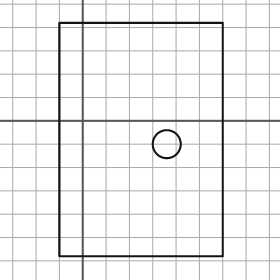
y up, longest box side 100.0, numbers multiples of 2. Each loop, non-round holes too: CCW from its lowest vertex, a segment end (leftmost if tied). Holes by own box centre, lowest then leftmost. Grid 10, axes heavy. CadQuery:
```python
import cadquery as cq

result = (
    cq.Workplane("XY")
    .moveTo(-10.0, -58.0)
    .lineTo(60.0, -58.0)
    .lineTo(60.0, 42.0)
    .lineTo(-10.0, 42.0)
    .close()
    .moveTo(36.0, -10.0)
    .circle(6.0)
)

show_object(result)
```